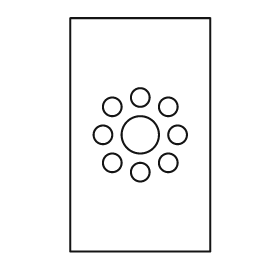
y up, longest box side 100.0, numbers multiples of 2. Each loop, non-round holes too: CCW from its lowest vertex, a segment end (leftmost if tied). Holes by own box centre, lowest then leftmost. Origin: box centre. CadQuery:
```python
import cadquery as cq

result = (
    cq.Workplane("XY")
    .moveTo(-30.0, -50.0)
    .lineTo(30.0, -50.0)
    .lineTo(30.0, 50.0)
    .lineTo(-30.0, 50.0)
    .close()
    .moveTo(0.0, -16.0)
    .circle(4.0)
    .moveTo(-12.0, -12.0)
    .circle(4.0)
    .moveTo(12.0, -12.0)
    .circle(4.0)
    .moveTo(-16.0, 0.0)
    .circle(4.0)
    .moveTo(0.0, 0.0)
    .circle(8.0)
    .moveTo(16.0, 0.0)
    .circle(4.0)
    .moveTo(-12.0, 12.0)
    .circle(4.0)
    .moveTo(12.0, 12.0)
    .circle(4.0)
    .moveTo(0.0, 16.0)
    .circle(4.0)
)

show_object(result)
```